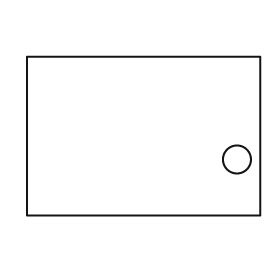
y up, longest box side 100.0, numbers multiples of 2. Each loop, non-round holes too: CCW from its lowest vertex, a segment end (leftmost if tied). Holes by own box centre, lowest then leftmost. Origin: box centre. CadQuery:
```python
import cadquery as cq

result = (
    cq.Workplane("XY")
    .moveTo(-50.0, -34.0)
    .lineTo(50.0, -34.0)
    .lineTo(50.0, 34.0)
    .lineTo(-50.0, 34.0)
    .close()
    .moveTo(40.0, -10.0)
    .circle(6.0)
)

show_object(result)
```